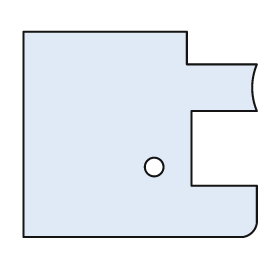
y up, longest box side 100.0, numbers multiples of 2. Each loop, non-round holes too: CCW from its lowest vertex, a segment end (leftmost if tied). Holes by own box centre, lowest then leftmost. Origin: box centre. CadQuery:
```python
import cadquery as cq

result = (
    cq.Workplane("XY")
    .moveTo(-50.0, -44.0)
    .lineTo(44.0, -44.0)
    .threePointArc((48.0, -42.0), (50.0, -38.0))
    .lineTo(50.0, -22.0)
    .lineTo(22.0, -22.0)
    .lineTo(22.0, 10.0)
    .lineTo(50.0, 10.0)
    .threePointArc((48.0, 20.0), (50.0, 30.0))
    .lineTo(20.0, 30.0)
    .lineTo(20.0, 44.0)
    .lineTo(-50.0, 44.0)
    .close()
    .moveTo(6.0, -14.0)
    .circle(4.0)
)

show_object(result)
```